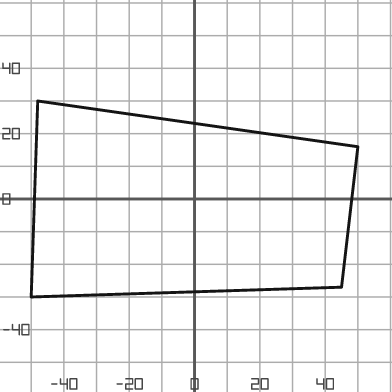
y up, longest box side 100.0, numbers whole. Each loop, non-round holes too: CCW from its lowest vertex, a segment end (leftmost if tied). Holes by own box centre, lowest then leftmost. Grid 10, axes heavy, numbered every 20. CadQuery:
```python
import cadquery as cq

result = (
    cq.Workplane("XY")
    .moveTo(-50.0, -30.0)
    .lineTo(45.0, -27.0)
    .lineTo(50.0, 16.0)
    .lineTo(-48.0, 30.0)
    .close()
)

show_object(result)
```